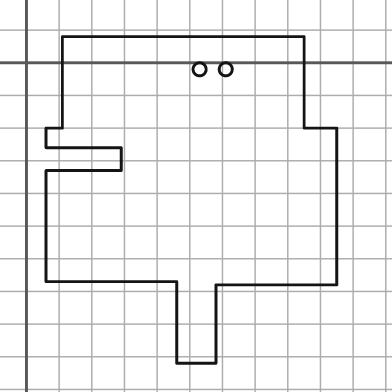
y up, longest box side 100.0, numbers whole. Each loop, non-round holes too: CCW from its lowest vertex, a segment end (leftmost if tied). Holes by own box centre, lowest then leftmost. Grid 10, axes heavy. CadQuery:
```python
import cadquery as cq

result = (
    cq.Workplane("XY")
    .moveTo(46.0, -92.0)
    .lineTo(58.0, -92.0)
    .lineTo(58.0, -68.0)
    .lineTo(95.0, -68.0)
    .lineTo(95.0, -20.0)
    .lineTo(85.0, -20.0)
    .lineTo(85.0, 8.0)
    .lineTo(11.0, 8.0)
    .lineTo(11.0, -20.0)
    .lineTo(6.0, -20.0)
    .lineTo(6.0, -26.0)
    .lineTo(29.0, -26.0)
    .lineTo(29.0, -33.0)
    .lineTo(6.0, -33.0)
    .lineTo(6.0, -67.0)
    .lineTo(46.0, -67.0)
    .close()
    .moveTo(53.0, -2.0)
    .circle(2.0)
    .moveTo(61.0, -2.0)
    .circle(2.0)
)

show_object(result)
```